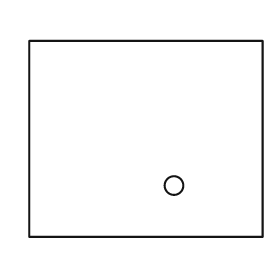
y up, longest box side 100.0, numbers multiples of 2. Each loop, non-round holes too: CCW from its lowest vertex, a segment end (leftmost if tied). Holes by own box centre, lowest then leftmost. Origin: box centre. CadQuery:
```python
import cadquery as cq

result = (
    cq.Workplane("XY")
    .moveTo(-50.0, -42.0)
    .lineTo(50.0, -42.0)
    .lineTo(50.0, 42.0)
    .lineTo(-50.0, 42.0)
    .close()
    .moveTo(12.0, -20.0)
    .circle(4.0)
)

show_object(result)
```